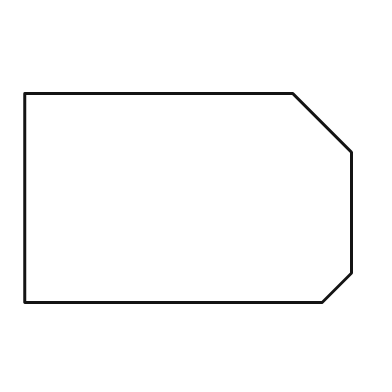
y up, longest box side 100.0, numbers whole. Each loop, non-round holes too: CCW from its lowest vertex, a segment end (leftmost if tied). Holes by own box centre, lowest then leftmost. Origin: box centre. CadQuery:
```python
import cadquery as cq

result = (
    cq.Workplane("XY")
    .moveTo(-50.0, -32.0)
    .lineTo(41.0, -32.0)
    .lineTo(50.0, -23.0)
    .lineTo(50.0, 14.0)
    .lineTo(32.0, 32.0)
    .lineTo(-50.0, 32.0)
    .close()
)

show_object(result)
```